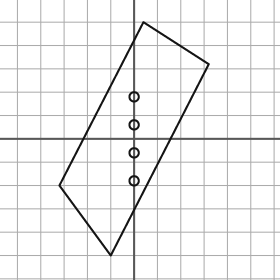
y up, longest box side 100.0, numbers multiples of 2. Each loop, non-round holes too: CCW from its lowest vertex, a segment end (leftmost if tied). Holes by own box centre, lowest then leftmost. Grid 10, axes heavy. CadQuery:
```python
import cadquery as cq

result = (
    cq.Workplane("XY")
    .moveTo(-10.0, -50.0)
    .lineTo(32.0, 32.0)
    .lineTo(4.0, 50.0)
    .lineTo(-32.0, -20.0)
    .close()
    .moveTo(0.0, -18.0)
    .circle(2.0)
    .moveTo(0.0, -6.0)
    .circle(2.0)
    .moveTo(0.0, 6.0)
    .circle(2.0)
    .moveTo(0.0, 18.0)
    .circle(2.0)
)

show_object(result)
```